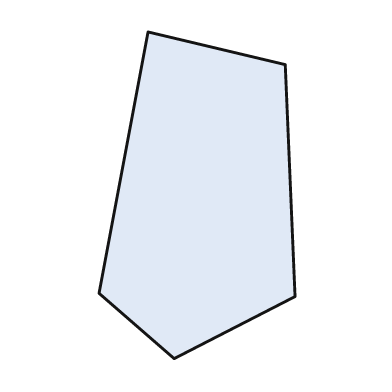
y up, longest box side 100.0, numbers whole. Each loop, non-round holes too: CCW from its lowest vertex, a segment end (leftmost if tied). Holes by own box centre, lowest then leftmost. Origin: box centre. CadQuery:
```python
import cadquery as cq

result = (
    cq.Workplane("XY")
    .moveTo(-7.0, -50.0)
    .lineTo(30.0, -31.0)
    .lineTo(27.0, 40.0)
    .lineTo(-15.0, 50.0)
    .lineTo(-30.0, -30.0)
    .close()
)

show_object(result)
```